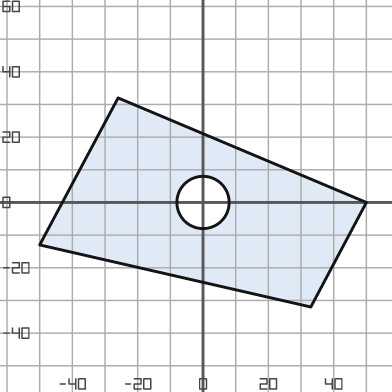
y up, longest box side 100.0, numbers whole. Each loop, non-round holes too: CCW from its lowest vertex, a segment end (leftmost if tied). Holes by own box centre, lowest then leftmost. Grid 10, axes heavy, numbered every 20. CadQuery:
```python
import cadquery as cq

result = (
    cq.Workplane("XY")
    .moveTo(33.0, -32.0)
    .lineTo(50.0, 0.0)
    .lineTo(-26.0, 32.0)
    .lineTo(-50.0, -13.0)
    .close()
    .moveTo(0.0, 0.0)
    .circle(8.0)
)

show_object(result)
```